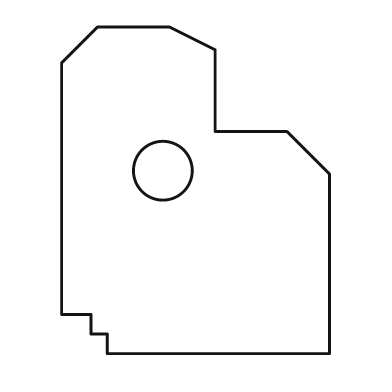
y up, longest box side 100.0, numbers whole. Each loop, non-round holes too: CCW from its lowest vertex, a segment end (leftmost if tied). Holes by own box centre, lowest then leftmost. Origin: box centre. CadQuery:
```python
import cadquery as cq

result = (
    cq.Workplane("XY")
    .moveTo(-27.0, -50.0)
    .lineTo(41.0, -50.0)
    .lineTo(41.0, 5.0)
    .lineTo(28.0, 18.0)
    .lineTo(6.0, 18.0)
    .lineTo(6.0, 43.0)
    .lineTo(-8.0, 50.0)
    .lineTo(-30.0, 50.0)
    .lineTo(-41.0, 39.0)
    .lineTo(-41.0, -38.0)
    .lineTo(-32.0, -38.0)
    .lineTo(-32.0, -44.0)
    .lineTo(-27.0, -44.0)
    .close()
    .moveTo(-10.0, 6.0)
    .circle(9.0)
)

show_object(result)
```